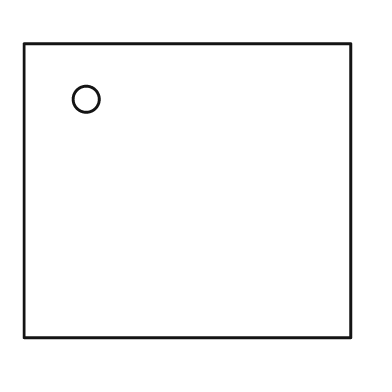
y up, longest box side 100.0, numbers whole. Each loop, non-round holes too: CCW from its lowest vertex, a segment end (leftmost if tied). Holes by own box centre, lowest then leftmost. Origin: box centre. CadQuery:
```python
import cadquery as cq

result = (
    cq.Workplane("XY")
    .moveTo(-50.0, -45.0)
    .lineTo(50.0, -45.0)
    .lineTo(50.0, 45.0)
    .lineTo(-50.0, 45.0)
    .close()
    .moveTo(-31.0, 28.0)
    .circle(4.0)
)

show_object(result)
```